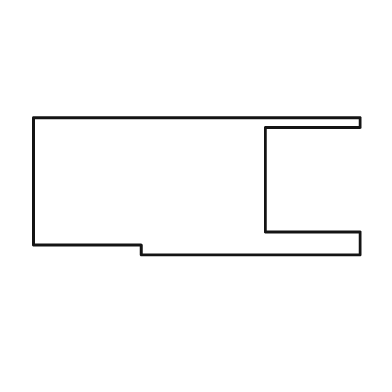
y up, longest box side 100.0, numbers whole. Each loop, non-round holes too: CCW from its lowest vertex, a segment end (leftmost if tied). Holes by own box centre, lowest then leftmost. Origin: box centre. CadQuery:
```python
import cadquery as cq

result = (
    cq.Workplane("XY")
    .moveTo(-17.0, -21.0)
    .lineTo(50.0, -21.0)
    .lineTo(50.0, -14.0)
    .lineTo(21.0, -14.0)
    .lineTo(21.0, 18.0)
    .lineTo(50.0, 18.0)
    .lineTo(50.0, 21.0)
    .lineTo(-50.0, 21.0)
    .lineTo(-50.0, -18.0)
    .lineTo(-17.0, -18.0)
    .close()
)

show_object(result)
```